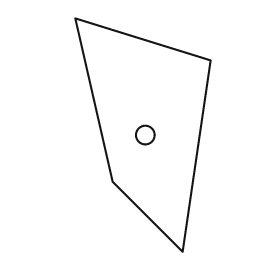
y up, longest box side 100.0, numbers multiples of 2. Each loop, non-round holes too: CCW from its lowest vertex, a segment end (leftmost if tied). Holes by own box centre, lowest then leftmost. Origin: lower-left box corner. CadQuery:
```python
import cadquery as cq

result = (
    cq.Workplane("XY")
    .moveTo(46.0, 0.0)
    .lineTo(58.0, 82.0)
    .lineTo(0.0, 100.0)
    .lineTo(16.0, 30.0)
    .close()
    .moveTo(30.0, 50.0)
    .circle(4.0)
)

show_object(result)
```